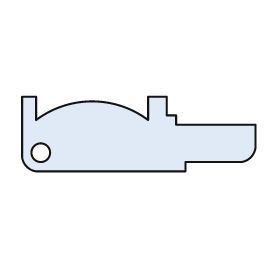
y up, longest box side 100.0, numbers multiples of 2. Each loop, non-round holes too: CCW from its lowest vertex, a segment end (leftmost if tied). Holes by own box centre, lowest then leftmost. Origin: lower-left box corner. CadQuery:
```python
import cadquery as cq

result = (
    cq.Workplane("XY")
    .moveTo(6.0, 0.0)
    .lineTo(70.0, 0.0)
    .lineTo(70.0, 4.0)
    .lineTo(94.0, 4.0)
    .threePointArc((98.0, 6.0), (100.0, 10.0))
    .lineTo(100.0, 20.0)
    .lineTo(66.0, 20.0)
    .lineTo(66.0, 24.0)
    .lineTo(62.0, 24.0)
    .lineTo(62.0, 32.0)
    .lineTo(54.0, 32.0)
    .lineTo(54.0, 22.0)
    .threePointArc((30.0, 30.0), (6.0, 22.0))
    .lineTo(6.0, 32.0)
    .lineTo(0.0, 32.0)
    .lineTo(0.0, 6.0)
    .threePointArc((2.0, 2.0), (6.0, 0.0))
    .close()
    .moveTo(8.0, 8.0)
    .circle(4.0)
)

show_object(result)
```